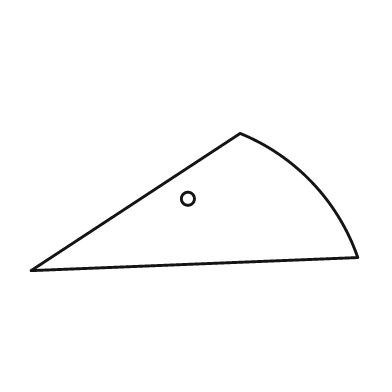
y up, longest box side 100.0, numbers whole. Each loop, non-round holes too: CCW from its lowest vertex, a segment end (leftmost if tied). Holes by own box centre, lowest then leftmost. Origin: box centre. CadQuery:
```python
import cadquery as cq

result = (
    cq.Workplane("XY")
    .moveTo(-50.0, -21.0)
    .lineTo(50.0, -17.0)
    .threePointArc((36.0, 6.0), (14.0, 21.0))
    .close()
    .moveTo(-2.0, 1.0)
    .circle(2.0)
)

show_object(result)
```